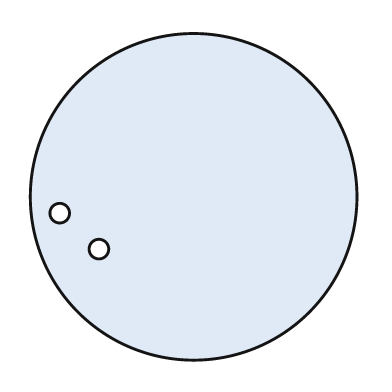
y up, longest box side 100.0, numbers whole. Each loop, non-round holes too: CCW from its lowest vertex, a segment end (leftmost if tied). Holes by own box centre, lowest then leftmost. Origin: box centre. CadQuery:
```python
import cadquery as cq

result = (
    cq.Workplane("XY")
    .moveTo(0.0, 0.0)
    .circle(50.0)
    .moveTo(-29.0, -16.0)
    .circle(3.0)
    .moveTo(-41.0, -5.0)
    .circle(3.0)
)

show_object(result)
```